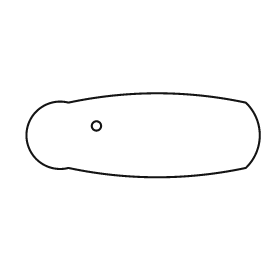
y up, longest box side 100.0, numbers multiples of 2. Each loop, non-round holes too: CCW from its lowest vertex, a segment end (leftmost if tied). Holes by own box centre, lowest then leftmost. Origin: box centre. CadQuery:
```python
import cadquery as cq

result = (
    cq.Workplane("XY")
    .moveTo(-32.0, -14.0)
    .threePointArc((6.0, -18.0), (44.0, -14.0))
    .threePointArc((50.0, 0.0), (44.0, 14.0))
    .threePointArc((6.0, 18.0), (-32.0, 14.0))
    .threePointArc((-50.0, 0.0), (-32.0, -14.0))
    .close()
    .moveTo(-20.0, 4.0)
    .circle(2.0)
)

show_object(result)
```